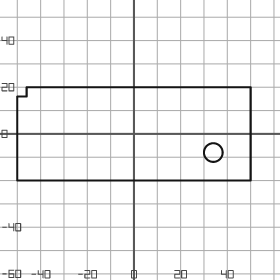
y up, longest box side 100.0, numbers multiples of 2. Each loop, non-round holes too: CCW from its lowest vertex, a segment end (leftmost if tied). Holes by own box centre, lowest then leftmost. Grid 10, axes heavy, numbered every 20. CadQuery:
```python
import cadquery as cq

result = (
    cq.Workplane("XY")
    .moveTo(-50.0, -20.0)
    .lineTo(50.0, -20.0)
    .lineTo(50.0, 20.0)
    .lineTo(-46.0, 20.0)
    .lineTo(-46.0, 16.0)
    .lineTo(-50.0, 16.0)
    .close()
    .moveTo(34.0, -8.0)
    .circle(4.0)
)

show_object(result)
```